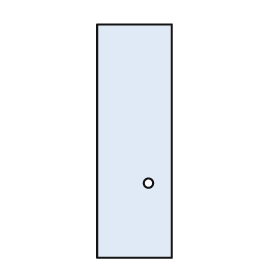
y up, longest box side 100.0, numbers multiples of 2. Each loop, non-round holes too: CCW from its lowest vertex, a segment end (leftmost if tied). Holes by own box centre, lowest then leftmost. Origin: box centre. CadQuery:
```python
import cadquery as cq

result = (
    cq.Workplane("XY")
    .moveTo(-16.0, -50.0)
    .lineTo(16.0, -50.0)
    .lineTo(16.0, 50.0)
    .lineTo(-16.0, 50.0)
    .close()
    .moveTo(6.0, -18.0)
    .circle(2.0)
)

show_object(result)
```